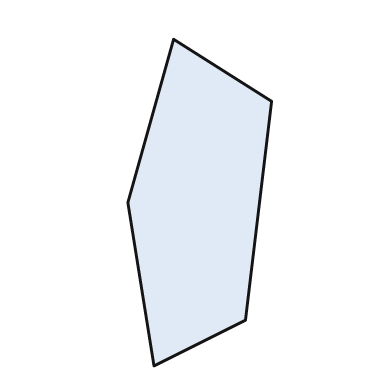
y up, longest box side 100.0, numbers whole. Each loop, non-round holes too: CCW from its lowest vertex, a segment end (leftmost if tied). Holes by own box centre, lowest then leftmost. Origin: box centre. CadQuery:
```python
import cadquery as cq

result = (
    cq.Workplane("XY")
    .moveTo(-14.0, -50.0)
    .lineTo(14.0, -36.0)
    .lineTo(22.0, 31.0)
    .lineTo(-8.0, 50.0)
    .lineTo(-22.0, 0.0)
    .close()
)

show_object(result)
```